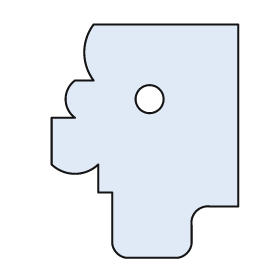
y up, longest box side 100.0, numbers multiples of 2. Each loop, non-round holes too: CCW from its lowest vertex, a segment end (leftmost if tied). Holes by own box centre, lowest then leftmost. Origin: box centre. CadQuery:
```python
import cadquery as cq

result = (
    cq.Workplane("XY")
    .moveTo(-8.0, -50.0)
    .lineTo(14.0, -50.0)
    .threePointArc((18.0, -48.0), (20.0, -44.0))
    .lineTo(20.0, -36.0)
    .threePointArc((22.0, -30.0), (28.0, -28.0))
    .lineTo(40.0, -28.0)
    .lineTo(40.0, 50.0)
    .lineTo(-22.0, 50.0)
    .threePointArc((-26.0, 38.0), (-22.0, 26.0))
    .lineTo(-30.0, 26.0)
    .threePointArc((-34.0, 18.0), (-30.0, 10.0))
    .lineTo(-40.0, 10.0)
    .lineTo(-40.0, -10.0)
    .threePointArc((-30.0, -14.0), (-20.0, -10.0))
    .lineTo(-20.0, -22.0)
    .lineTo(-14.0, -22.0)
    .lineTo(-14.0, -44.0)
    .threePointArc((-12.0, -48.0), (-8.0, -50.0))
    .close()
    .moveTo(2.0, 18.0)
    .circle(6.0)
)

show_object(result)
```